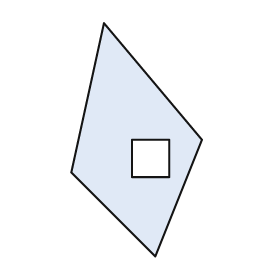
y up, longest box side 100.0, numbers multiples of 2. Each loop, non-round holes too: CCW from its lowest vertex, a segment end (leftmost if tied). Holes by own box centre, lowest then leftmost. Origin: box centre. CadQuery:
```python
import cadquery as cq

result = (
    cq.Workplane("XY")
    .moveTo(8.0, -50.0)
    .lineTo(28.0, 0.0)
    .lineTo(-14.0, 50.0)
    .lineTo(-28.0, -14.0)
    .close()
    .moveTo(-2.0, -16.0)
    .lineTo(14.0, -16.0)
    .lineTo(14.0, 0.0)
    .lineTo(-2.0, 0.0)
    .close()
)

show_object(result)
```